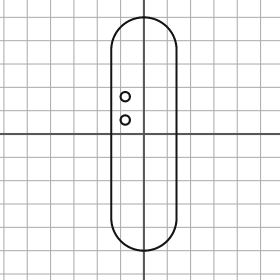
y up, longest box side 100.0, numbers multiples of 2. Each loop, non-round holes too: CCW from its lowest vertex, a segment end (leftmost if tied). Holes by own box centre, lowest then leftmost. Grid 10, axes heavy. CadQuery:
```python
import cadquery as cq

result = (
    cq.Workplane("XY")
    .moveTo(-14.0, -36.0)
    .threePointArc((0.0, -50.0), (14.0, -36.0))
    .lineTo(14.0, 36.0)
    .threePointArc((0.0, 50.0), (-14.0, 36.0))
    .close()
    .moveTo(-8.0, 6.0)
    .circle(2.0)
    .moveTo(-8.0, 16.0)
    .circle(2.0)
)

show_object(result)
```